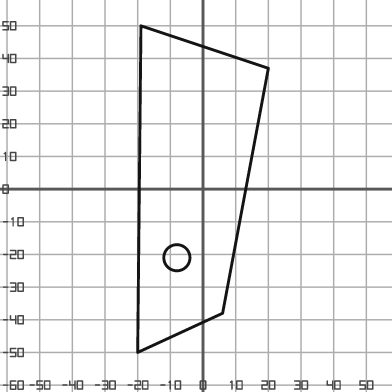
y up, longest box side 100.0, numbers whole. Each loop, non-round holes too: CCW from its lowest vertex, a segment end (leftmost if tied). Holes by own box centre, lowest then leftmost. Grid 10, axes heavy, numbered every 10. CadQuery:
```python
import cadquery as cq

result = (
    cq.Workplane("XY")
    .moveTo(-20.0, -50.0)
    .lineTo(6.0, -38.0)
    .lineTo(20.0, 37.0)
    .lineTo(-19.0, 50.0)
    .close()
    .moveTo(-8.0, -21.0)
    .circle(4.0)
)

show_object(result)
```